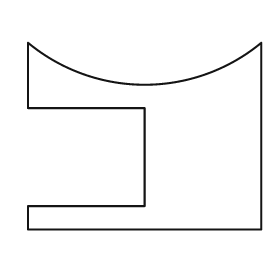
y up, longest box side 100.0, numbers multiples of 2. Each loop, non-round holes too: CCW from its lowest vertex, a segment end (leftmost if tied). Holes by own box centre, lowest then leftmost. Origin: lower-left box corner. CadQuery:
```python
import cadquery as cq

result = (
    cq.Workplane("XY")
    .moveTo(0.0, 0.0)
    .lineTo(100.0, 0.0)
    .lineTo(100.0, 80.0)
    .threePointArc((50.0, 62.0), (0.0, 80.0))
    .lineTo(0.0, 52.0)
    .lineTo(50.0, 52.0)
    .lineTo(50.0, 10.0)
    .lineTo(0.0, 10.0)
    .close()
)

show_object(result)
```